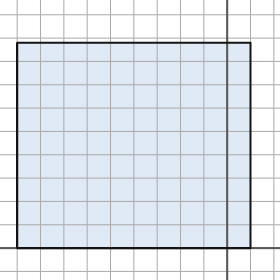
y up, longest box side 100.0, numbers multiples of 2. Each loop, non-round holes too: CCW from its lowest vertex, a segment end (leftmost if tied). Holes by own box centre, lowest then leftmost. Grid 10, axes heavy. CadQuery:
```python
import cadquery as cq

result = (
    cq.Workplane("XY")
    .moveTo(-90.0, 0.0)
    .lineTo(10.0, 0.0)
    .lineTo(10.0, 88.0)
    .lineTo(-90.0, 88.0)
    .close()
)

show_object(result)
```